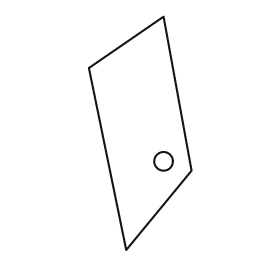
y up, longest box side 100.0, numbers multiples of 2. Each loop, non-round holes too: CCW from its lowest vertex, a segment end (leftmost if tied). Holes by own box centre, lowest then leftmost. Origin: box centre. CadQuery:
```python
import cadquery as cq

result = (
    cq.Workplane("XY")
    .moveTo(-6.0, -50.0)
    .lineTo(22.0, -16.0)
    .lineTo(10.0, 50.0)
    .lineTo(-22.0, 28.0)
    .close()
    .moveTo(10.0, -12.0)
    .circle(4.0)
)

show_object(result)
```